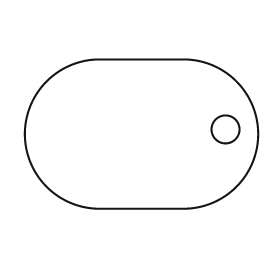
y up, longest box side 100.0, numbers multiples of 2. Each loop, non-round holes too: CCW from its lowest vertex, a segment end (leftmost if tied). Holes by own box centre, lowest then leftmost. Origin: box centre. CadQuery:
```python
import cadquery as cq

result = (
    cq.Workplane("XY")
    .moveTo(-18.0, -32.0)
    .lineTo(18.0, -32.0)
    .threePointArc((50.0, 0.0), (18.0, 32.0))
    .lineTo(-18.0, 32.0)
    .threePointArc((-50.0, 0.0), (-18.0, -32.0))
    .close()
    .moveTo(36.0, 2.0)
    .circle(6.0)
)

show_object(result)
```